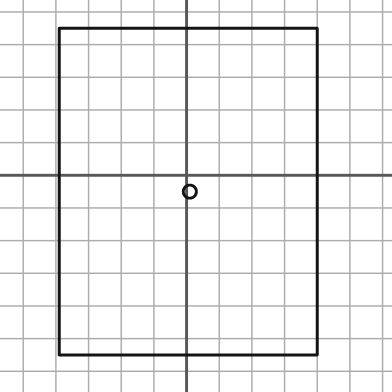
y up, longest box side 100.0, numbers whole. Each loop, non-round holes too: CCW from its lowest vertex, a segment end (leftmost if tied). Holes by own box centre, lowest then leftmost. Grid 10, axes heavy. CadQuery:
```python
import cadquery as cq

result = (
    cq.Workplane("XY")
    .moveTo(-39.0, -55.0)
    .lineTo(40.0, -55.0)
    .lineTo(40.0, 45.0)
    .lineTo(-39.0, 45.0)
    .close()
    .moveTo(1.0, -5.0)
    .circle(2.0)
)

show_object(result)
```